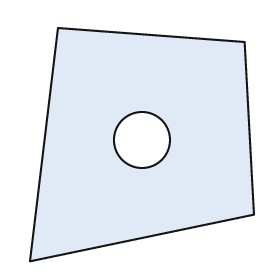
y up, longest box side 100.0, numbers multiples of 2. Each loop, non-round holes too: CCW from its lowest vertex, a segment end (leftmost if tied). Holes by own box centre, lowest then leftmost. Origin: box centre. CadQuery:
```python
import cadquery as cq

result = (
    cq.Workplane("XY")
    .moveTo(-48.0, -50.0)
    .lineTo(48.0, -30.0)
    .lineTo(44.0, 44.0)
    .lineTo(-36.0, 50.0)
    .close()
    .moveTo(0.0, 2.0)
    .circle(12.0)
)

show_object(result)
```